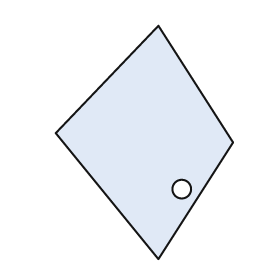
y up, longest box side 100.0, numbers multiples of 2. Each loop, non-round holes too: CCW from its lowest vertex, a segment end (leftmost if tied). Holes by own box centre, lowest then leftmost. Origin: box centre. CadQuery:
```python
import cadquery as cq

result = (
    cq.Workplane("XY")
    .moveTo(6.0, -50.0)
    .lineTo(38.0, 0.0)
    .lineTo(6.0, 50.0)
    .lineTo(-38.0, 4.0)
    .close()
    .moveTo(16.0, -20.0)
    .circle(4.0)
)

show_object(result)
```